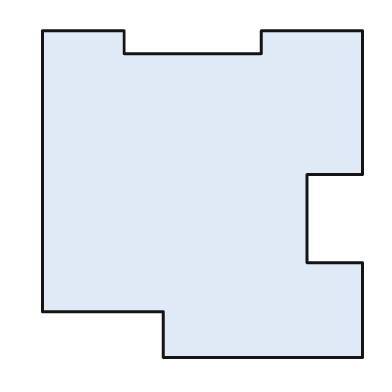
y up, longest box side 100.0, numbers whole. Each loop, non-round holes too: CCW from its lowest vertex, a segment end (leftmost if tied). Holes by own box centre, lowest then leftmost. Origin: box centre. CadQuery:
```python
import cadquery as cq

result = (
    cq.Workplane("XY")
    .moveTo(-12.0, -50.0)
    .lineTo(49.0, -50.0)
    .lineTo(49.0, -21.0)
    .lineTo(32.0, -21.0)
    .lineTo(32.0, 6.0)
    .lineTo(49.0, 6.0)
    .lineTo(49.0, 50.0)
    .lineTo(18.0, 50.0)
    .lineTo(18.0, 43.0)
    .lineTo(-24.0, 43.0)
    .lineTo(-24.0, 50.0)
    .lineTo(-49.0, 50.0)
    .lineTo(-49.0, -36.0)
    .lineTo(-12.0, -36.0)
    .close()
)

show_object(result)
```